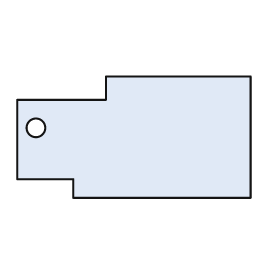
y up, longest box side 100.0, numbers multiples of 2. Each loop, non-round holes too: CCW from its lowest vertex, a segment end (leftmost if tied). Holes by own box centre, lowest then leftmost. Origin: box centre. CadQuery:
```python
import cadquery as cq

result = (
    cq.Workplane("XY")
    .moveTo(-26.0, -26.0)
    .lineTo(50.0, -26.0)
    .lineTo(50.0, 26.0)
    .lineTo(-12.0, 26.0)
    .lineTo(-12.0, 16.0)
    .lineTo(-50.0, 16.0)
    .lineTo(-50.0, -18.0)
    .lineTo(-26.0, -18.0)
    .close()
    .moveTo(-42.0, 4.0)
    .circle(4.0)
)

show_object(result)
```